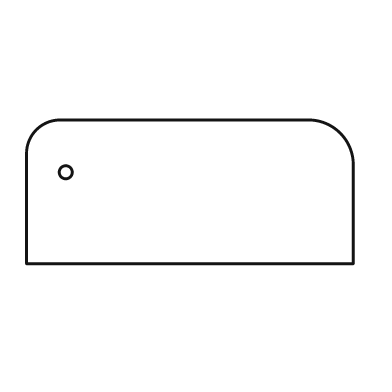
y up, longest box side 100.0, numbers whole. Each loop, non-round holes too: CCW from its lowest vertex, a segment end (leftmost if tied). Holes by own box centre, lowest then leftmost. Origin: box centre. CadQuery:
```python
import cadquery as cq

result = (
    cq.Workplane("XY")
    .moveTo(-50.0, -22.0)
    .lineTo(50.0, -22.0)
    .lineTo(50.0, 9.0)
    .threePointArc((46.0, 18.0), (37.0, 22.0))
    .lineTo(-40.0, 22.0)
    .threePointArc((-47.0, 19.0), (-50.0, 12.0))
    .close()
    .moveTo(-38.0, 6.0)
    .circle(2.0)
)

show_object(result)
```